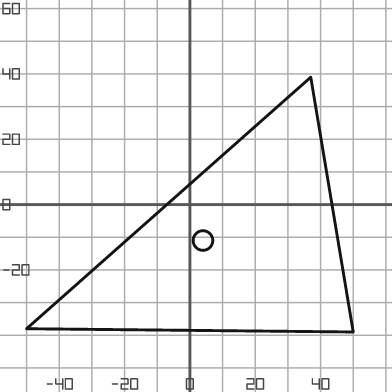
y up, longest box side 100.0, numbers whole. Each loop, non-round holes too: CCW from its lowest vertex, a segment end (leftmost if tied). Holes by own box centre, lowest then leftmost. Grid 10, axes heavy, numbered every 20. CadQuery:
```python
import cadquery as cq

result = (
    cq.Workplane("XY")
    .moveTo(50.0, -39.0)
    .lineTo(37.0, 39.0)
    .lineTo(-50.0, -38.0)
    .close()
    .moveTo(4.0, -11.0)
    .circle(3.0)
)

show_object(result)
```